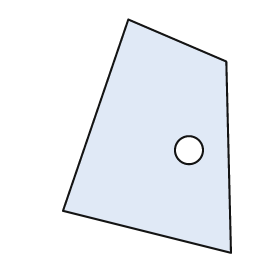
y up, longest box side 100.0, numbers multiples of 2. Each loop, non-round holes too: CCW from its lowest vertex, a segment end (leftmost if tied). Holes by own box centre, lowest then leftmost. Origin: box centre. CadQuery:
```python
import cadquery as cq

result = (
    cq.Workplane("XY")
    .moveTo(36.0, -50.0)
    .lineTo(34.0, 32.0)
    .lineTo(-8.0, 50.0)
    .lineTo(-36.0, -32.0)
    .close()
    .moveTo(18.0, -6.0)
    .circle(6.0)
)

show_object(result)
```